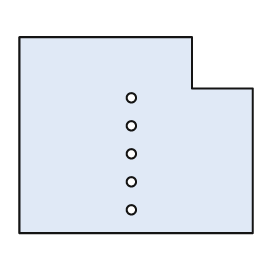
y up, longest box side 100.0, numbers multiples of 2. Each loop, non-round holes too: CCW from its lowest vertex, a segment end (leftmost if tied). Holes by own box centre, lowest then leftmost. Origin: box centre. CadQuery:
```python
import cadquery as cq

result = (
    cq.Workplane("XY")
    .moveTo(-50.0, -42.0)
    .lineTo(50.0, -42.0)
    .lineTo(50.0, 20.0)
    .lineTo(24.0, 20.0)
    .lineTo(24.0, 42.0)
    .lineTo(-50.0, 42.0)
    .close()
    .moveTo(-2.0, -32.0)
    .circle(2.0)
    .moveTo(-2.0, -20.0)
    .circle(2.0)
    .moveTo(-2.0, -8.0)
    .circle(2.0)
    .moveTo(-2.0, 4.0)
    .circle(2.0)
    .moveTo(-2.0, 16.0)
    .circle(2.0)
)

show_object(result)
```